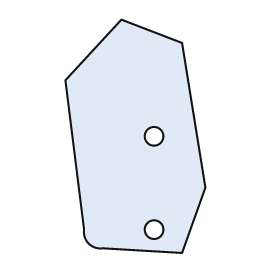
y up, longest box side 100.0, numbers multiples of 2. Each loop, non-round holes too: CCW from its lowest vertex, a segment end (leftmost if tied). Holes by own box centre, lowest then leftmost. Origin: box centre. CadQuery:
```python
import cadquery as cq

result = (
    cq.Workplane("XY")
    .moveTo(20.0, -50.0)
    .lineTo(30.0, -22.0)
    .lineTo(20.0, 40.0)
    .lineTo(-6.0, 50.0)
    .lineTo(-30.0, 24.0)
    .lineTo(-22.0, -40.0)
    .threePointArc((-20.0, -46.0), (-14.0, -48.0))
    .close()
    .moveTo(8.0, -40.0)
    .circle(4.0)
    .moveTo(8.0, 0.0)
    .circle(4.0)
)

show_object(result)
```